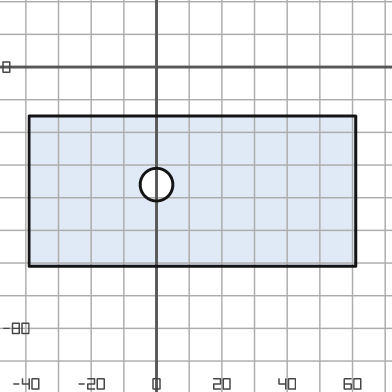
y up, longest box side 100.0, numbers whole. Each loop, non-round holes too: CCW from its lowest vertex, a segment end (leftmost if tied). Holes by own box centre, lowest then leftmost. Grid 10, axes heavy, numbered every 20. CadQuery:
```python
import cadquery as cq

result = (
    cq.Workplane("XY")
    .moveTo(-39.0, -61.0)
    .lineTo(61.0, -61.0)
    .lineTo(61.0, -15.0)
    .lineTo(-39.0, -15.0)
    .close()
    .moveTo(0.0, -36.0)
    .circle(5.0)
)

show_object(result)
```